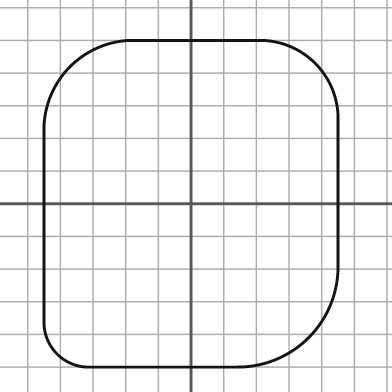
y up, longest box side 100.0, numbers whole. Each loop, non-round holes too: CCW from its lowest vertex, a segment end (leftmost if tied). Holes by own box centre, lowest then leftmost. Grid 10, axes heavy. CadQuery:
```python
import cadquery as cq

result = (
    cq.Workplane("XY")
    .moveTo(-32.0, -50.0)
    .lineTo(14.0, -50.0)
    .threePointArc((36.0, -41.0), (45.0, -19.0))
    .lineTo(45.0, 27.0)
    .threePointArc((38.0, 43.0), (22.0, 50.0))
    .lineTo(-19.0, 50.0)
    .threePointArc((-37.0, 42.0), (-45.0, 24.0))
    .lineTo(-45.0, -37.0)
    .threePointArc((-41.0, -46.0), (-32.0, -50.0))
    .close()
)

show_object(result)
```